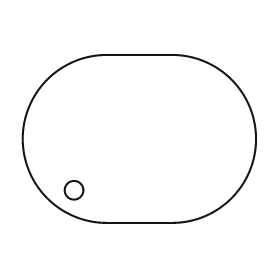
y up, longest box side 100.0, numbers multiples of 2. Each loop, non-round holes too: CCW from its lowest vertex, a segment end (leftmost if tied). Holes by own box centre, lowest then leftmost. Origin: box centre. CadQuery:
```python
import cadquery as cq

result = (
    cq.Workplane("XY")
    .moveTo(-14.0, -36.0)
    .lineTo(14.0, -36.0)
    .threePointArc((50.0, 0.0), (14.0, 36.0))
    .lineTo(-14.0, 36.0)
    .threePointArc((-50.0, 0.0), (-14.0, -36.0))
    .close()
    .moveTo(-28.0, -22.0)
    .circle(4.0)
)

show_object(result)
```